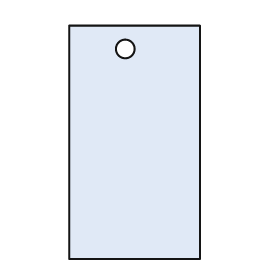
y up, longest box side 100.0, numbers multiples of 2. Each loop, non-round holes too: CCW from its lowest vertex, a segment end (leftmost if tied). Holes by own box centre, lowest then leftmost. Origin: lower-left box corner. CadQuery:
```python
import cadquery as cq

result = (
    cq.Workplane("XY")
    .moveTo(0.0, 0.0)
    .lineTo(56.0, 0.0)
    .lineTo(56.0, 100.0)
    .lineTo(0.0, 100.0)
    .close()
    .moveTo(24.0, 90.0)
    .circle(4.0)
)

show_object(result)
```